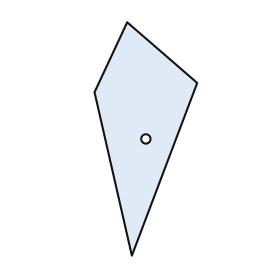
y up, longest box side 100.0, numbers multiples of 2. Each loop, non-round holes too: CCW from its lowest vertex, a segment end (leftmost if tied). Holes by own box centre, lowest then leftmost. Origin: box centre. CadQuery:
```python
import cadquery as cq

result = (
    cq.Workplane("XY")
    .moveTo(-6.0, -50.0)
    .lineTo(22.0, 24.0)
    .lineTo(-8.0, 50.0)
    .lineTo(-22.0, 20.0)
    .close()
    .moveTo(0.0, 0.0)
    .circle(2.0)
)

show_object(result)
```